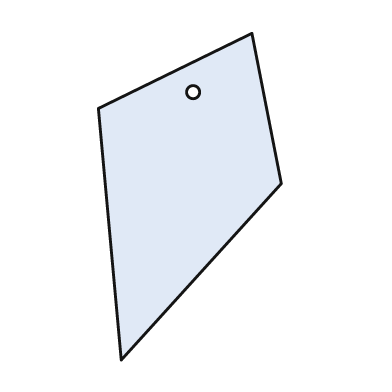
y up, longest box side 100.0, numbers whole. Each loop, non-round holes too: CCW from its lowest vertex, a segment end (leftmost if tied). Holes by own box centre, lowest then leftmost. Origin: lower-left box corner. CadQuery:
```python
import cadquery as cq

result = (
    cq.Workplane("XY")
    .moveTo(7.0, 0.0)
    .lineTo(56.0, 54.0)
    .lineTo(47.0, 100.0)
    .lineTo(0.0, 77.0)
    .close()
    .moveTo(29.0, 82.0)
    .circle(2.0)
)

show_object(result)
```